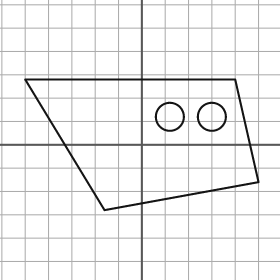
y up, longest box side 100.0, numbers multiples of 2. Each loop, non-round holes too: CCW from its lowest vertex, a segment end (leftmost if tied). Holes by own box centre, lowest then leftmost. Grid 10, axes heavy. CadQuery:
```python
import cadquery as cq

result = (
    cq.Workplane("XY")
    .moveTo(-16.0, -28.0)
    .lineTo(50.0, -16.0)
    .lineTo(40.0, 28.0)
    .lineTo(-50.0, 28.0)
    .close()
    .moveTo(12.0, 12.0)
    .circle(6.0)
    .moveTo(30.0, 12.0)
    .circle(6.0)
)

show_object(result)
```